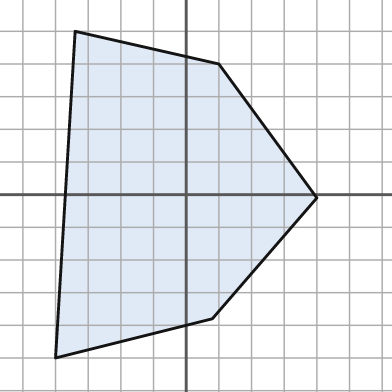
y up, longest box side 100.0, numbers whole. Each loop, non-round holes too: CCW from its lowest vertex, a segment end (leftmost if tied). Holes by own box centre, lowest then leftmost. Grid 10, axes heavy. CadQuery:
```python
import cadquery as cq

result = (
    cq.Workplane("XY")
    .moveTo(-40.0, -50.0)
    .lineTo(8.0, -38.0)
    .lineTo(40.0, -1.0)
    .lineTo(10.0, 40.0)
    .lineTo(-34.0, 50.0)
    .close()
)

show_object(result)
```